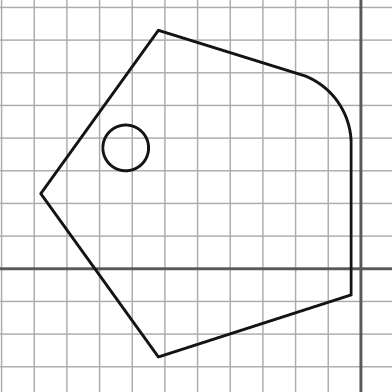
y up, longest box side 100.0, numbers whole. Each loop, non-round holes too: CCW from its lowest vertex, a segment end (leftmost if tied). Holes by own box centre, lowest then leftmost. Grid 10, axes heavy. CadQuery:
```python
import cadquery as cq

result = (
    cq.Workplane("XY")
    .moveTo(-62.0, -27.0)
    .lineTo(-3.0, -8.0)
    .lineTo(-3.0, 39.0)
    .threePointArc((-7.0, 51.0), (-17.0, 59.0))
    .lineTo(-62.0, 73.0)
    .lineTo(-98.0, 23.0)
    .close()
    .moveTo(-72.0, 37.0)
    .circle(7.0)
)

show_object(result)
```